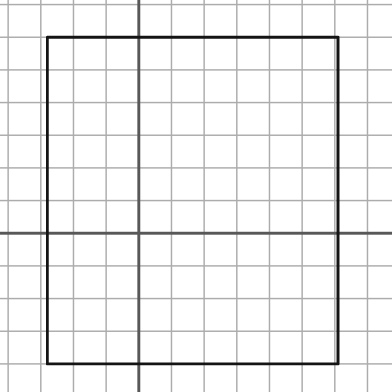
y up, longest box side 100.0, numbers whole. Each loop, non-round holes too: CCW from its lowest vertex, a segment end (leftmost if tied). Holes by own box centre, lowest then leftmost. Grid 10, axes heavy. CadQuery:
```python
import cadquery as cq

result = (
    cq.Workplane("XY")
    .moveTo(-28.0, -40.0)
    .lineTo(61.0, -40.0)
    .lineTo(61.0, 60.0)
    .lineTo(-28.0, 60.0)
    .close()
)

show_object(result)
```